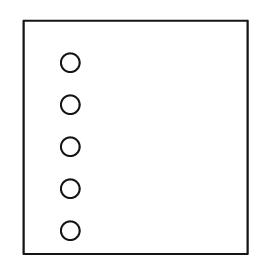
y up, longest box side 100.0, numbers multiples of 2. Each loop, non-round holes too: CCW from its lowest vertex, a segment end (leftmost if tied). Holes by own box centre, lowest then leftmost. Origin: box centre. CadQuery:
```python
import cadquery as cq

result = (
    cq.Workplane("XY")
    .moveTo(-48.0, -50.0)
    .lineTo(48.0, -50.0)
    .lineTo(48.0, 50.0)
    .lineTo(-48.0, 50.0)
    .close()
    .moveTo(-28.0, -40.0)
    .circle(4.0)
    .moveTo(-28.0, -22.0)
    .circle(4.0)
    .moveTo(-28.0, -4.0)
    .circle(4.0)
    .moveTo(-28.0, 14.0)
    .circle(4.0)
    .moveTo(-28.0, 32.0)
    .circle(4.0)
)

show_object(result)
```